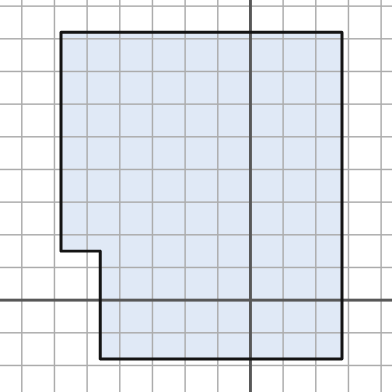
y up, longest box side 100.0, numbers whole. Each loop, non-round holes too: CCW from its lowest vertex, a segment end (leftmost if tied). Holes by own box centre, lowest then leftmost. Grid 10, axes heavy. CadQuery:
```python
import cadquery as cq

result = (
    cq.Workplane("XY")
    .moveTo(-46.0, -18.0)
    .lineTo(28.0, -18.0)
    .lineTo(28.0, 82.0)
    .lineTo(-58.0, 82.0)
    .lineTo(-58.0, 15.0)
    .lineTo(-46.0, 15.0)
    .close()
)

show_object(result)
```